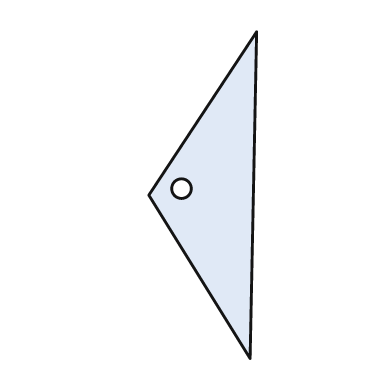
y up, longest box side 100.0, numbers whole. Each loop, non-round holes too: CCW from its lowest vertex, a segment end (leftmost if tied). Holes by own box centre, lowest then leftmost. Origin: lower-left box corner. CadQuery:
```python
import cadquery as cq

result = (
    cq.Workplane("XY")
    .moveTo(31.0, 0.0)
    .lineTo(33.0, 100.0)
    .lineTo(0.0, 50.0)
    .close()
    .moveTo(10.0, 52.0)
    .circle(3.0)
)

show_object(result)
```